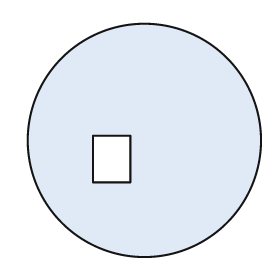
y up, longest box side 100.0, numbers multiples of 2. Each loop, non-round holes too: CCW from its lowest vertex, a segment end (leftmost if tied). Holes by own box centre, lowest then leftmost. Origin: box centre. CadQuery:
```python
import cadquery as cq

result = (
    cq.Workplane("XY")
    .moveTo(0.0, 0.0)
    .circle(50.0)
    .moveTo(-22.0, -18.0)
    .lineTo(-6.0, -18.0)
    .lineTo(-6.0, 2.0)
    .lineTo(-22.0, 2.0)
    .close()
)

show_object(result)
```